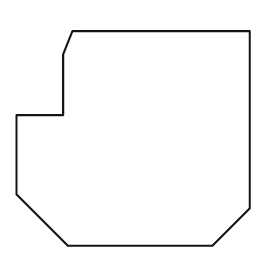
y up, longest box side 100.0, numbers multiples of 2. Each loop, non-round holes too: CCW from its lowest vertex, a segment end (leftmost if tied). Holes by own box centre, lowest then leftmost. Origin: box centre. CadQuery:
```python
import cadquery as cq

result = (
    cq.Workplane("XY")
    .moveTo(-28.0, -46.0)
    .lineTo(34.0, -46.0)
    .lineTo(50.0, -30.0)
    .lineTo(50.0, 46.0)
    .lineTo(-26.0, 46.0)
    .lineTo(-30.0, 36.0)
    .lineTo(-30.0, 10.0)
    .lineTo(-50.0, 10.0)
    .lineTo(-50.0, -24.0)
    .close()
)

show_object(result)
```